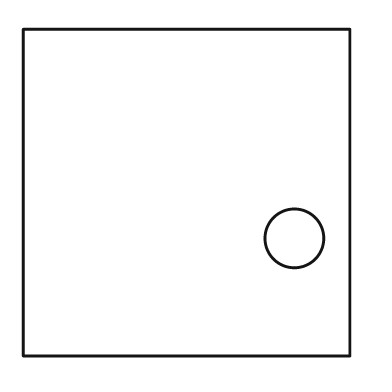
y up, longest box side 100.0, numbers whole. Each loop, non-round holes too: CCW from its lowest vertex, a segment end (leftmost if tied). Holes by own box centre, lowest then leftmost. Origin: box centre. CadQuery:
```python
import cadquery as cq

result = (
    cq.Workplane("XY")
    .moveTo(-50.0, -50.0)
    .lineTo(50.0, -50.0)
    .lineTo(50.0, 50.0)
    .lineTo(-50.0, 50.0)
    .close()
    .moveTo(33.0, -14.0)
    .circle(9.0)
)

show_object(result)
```